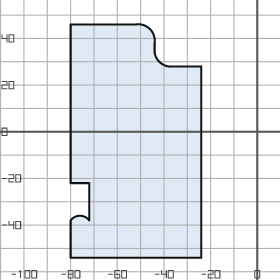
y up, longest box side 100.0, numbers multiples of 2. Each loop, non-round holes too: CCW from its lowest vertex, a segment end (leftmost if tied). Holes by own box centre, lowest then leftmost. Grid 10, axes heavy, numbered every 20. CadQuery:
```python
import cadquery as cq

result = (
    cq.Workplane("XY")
    .moveTo(-80.0, -54.0)
    .lineTo(-24.0, -54.0)
    .lineTo(-24.0, 28.0)
    .lineTo(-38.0, 28.0)
    .threePointArc((-42.0, 30.0), (-44.0, 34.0))
    .lineTo(-44.0, 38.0)
    .threePointArc((-46.0, 44.0), (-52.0, 46.0))
    .lineTo(-80.0, 46.0)
    .lineTo(-80.0, -22.0)
    .lineTo(-72.0, -22.0)
    .lineTo(-72.0, -38.0)
    .threePointArc((-76.0, -36.0), (-80.0, -38.0))
    .close()
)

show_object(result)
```